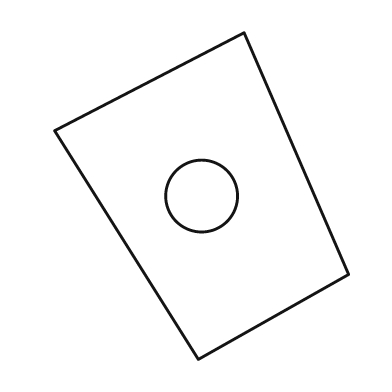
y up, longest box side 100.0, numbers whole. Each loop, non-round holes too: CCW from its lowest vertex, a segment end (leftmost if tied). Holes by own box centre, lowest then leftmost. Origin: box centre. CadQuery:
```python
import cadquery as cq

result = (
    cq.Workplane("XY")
    .moveTo(-1.0, -50.0)
    .lineTo(45.0, -24.0)
    .lineTo(13.0, 50.0)
    .lineTo(-45.0, 20.0)
    .close()
    .moveTo(0.0, 0.0)
    .circle(11.0)
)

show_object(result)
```